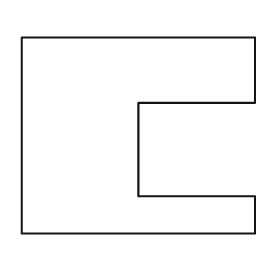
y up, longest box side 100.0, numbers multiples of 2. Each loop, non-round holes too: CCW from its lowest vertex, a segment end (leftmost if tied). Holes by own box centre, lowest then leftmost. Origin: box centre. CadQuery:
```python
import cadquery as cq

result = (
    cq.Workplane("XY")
    .moveTo(-50.0, -42.0)
    .lineTo(50.0, -42.0)
    .lineTo(50.0, -26.0)
    .lineTo(0.0, -26.0)
    .lineTo(0.0, 14.0)
    .lineTo(50.0, 14.0)
    .lineTo(50.0, 42.0)
    .lineTo(-50.0, 42.0)
    .close()
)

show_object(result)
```